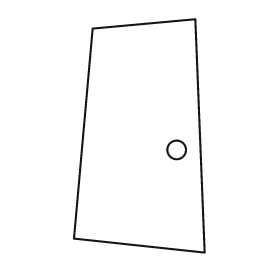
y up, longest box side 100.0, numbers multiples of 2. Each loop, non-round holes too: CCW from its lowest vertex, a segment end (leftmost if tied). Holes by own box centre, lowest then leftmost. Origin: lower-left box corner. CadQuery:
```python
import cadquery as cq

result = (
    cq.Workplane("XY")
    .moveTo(56.0, 0.0)
    .lineTo(52.0, 100.0)
    .lineTo(8.0, 96.0)
    .lineTo(0.0, 6.0)
    .close()
    .moveTo(44.0, 44.0)
    .circle(4.0)
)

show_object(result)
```